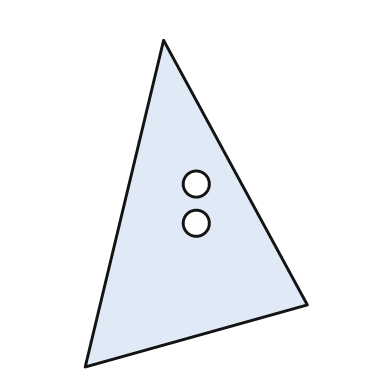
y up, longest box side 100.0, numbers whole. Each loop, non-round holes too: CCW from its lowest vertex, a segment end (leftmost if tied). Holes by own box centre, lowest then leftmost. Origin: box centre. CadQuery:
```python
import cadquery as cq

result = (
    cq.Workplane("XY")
    .moveTo(-34.0, -50.0)
    .lineTo(34.0, -31.0)
    .lineTo(-10.0, 50.0)
    .close()
    .moveTo(0.0, -6.0)
    .circle(4.0)
    .moveTo(0.0, 6.0)
    .circle(4.0)
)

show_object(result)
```